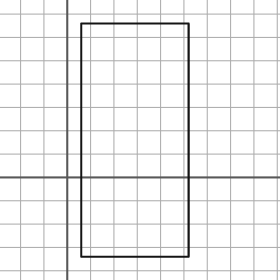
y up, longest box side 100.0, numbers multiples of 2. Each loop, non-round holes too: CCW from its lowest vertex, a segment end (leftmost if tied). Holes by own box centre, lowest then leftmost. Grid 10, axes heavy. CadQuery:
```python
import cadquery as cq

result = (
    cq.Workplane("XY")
    .moveTo(6.0, -34.0)
    .lineTo(52.0, -34.0)
    .lineTo(52.0, 66.0)
    .lineTo(6.0, 66.0)
    .close()
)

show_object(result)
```